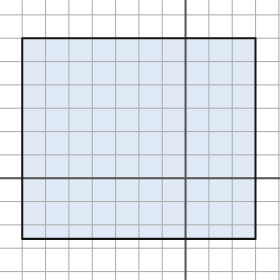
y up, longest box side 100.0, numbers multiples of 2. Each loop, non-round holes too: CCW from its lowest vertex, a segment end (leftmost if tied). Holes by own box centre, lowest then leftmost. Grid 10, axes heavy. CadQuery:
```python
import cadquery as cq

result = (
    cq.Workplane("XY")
    .moveTo(-70.0, -26.0)
    .lineTo(30.0, -26.0)
    .lineTo(30.0, 60.0)
    .lineTo(-70.0, 60.0)
    .close()
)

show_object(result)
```